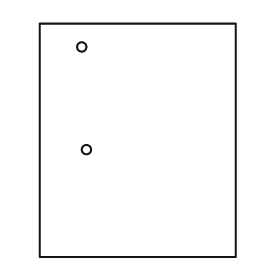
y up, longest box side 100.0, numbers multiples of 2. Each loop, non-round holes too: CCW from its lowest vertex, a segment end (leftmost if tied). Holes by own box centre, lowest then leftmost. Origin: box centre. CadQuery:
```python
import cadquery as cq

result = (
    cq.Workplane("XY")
    .moveTo(-42.0, -50.0)
    .lineTo(42.0, -50.0)
    .lineTo(42.0, 50.0)
    .lineTo(-42.0, 50.0)
    .close()
    .moveTo(-22.0, -4.0)
    .circle(2.0)
    .moveTo(-24.0, 40.0)
    .circle(2.0)
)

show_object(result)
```